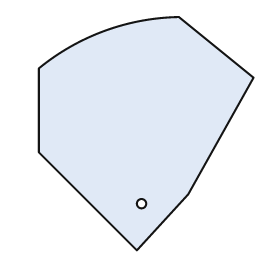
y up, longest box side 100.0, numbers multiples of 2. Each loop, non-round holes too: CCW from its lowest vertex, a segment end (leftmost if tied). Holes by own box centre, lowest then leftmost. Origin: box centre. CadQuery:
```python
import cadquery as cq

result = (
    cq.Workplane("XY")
    .moveTo(-4.0, -50.0)
    .lineTo(18.0, -26.0)
    .lineTo(46.0, 24.0)
    .lineTo(14.0, 50.0)
    .threePointArc((-18.0, 44.0), (-46.0, 28.0))
    .lineTo(-46.0, -8.0)
    .close()
    .moveTo(-2.0, -30.0)
    .circle(2.0)
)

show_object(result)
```